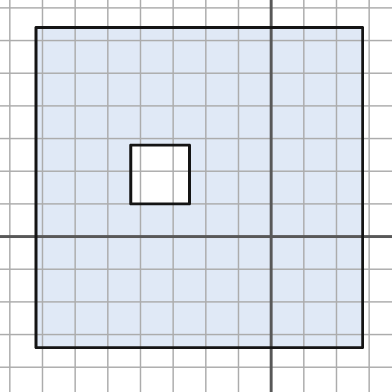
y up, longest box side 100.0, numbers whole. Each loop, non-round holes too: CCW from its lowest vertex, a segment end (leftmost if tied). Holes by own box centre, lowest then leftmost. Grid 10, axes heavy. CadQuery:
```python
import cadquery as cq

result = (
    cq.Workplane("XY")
    .moveTo(-72.0, -34.0)
    .lineTo(28.0, -34.0)
    .lineTo(28.0, 64.0)
    .lineTo(-72.0, 64.0)
    .close()
    .moveTo(-43.0, 10.0)
    .lineTo(-25.0, 10.0)
    .lineTo(-25.0, 28.0)
    .lineTo(-43.0, 28.0)
    .close()
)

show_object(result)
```